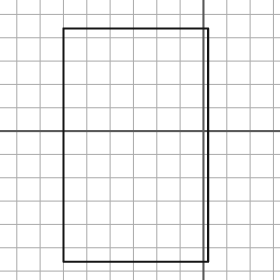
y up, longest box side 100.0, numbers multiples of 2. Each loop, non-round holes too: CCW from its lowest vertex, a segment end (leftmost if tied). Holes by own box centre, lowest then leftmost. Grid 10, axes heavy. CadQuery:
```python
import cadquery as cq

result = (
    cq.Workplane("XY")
    .moveTo(-60.0, -56.0)
    .lineTo(2.0, -56.0)
    .lineTo(2.0, 44.0)
    .lineTo(-60.0, 44.0)
    .close()
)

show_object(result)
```